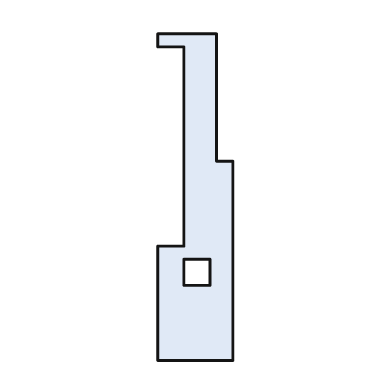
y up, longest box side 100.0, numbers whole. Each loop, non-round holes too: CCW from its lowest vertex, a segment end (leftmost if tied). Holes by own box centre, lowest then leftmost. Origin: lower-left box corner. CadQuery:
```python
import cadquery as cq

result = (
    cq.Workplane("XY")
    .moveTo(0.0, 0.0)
    .lineTo(23.0, 0.0)
    .lineTo(23.0, 61.0)
    .lineTo(18.0, 61.0)
    .lineTo(18.0, 100.0)
    .lineTo(0.0, 100.0)
    .lineTo(0.0, 96.0)
    .lineTo(8.0, 96.0)
    .lineTo(8.0, 35.0)
    .lineTo(0.0, 35.0)
    .close()
    .moveTo(8.0, 23.0)
    .lineTo(16.0, 23.0)
    .lineTo(16.0, 31.0)
    .lineTo(8.0, 31.0)
    .close()
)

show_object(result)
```